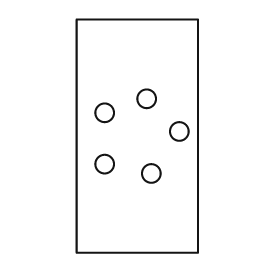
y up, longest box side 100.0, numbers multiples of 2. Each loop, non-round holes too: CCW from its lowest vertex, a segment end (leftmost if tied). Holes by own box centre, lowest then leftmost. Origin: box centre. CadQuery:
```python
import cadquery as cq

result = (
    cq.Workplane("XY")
    .moveTo(-26.0, -50.0)
    .lineTo(26.0, -50.0)
    .lineTo(26.0, 50.0)
    .lineTo(-26.0, 50.0)
    .close()
    .moveTo(6.0, -16.0)
    .circle(4.0)
    .moveTo(-14.0, -12.0)
    .circle(4.0)
    .moveTo(18.0, 2.0)
    .circle(4.0)
    .moveTo(-14.0, 10.0)
    .circle(4.0)
    .moveTo(4.0, 16.0)
    .circle(4.0)
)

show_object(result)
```